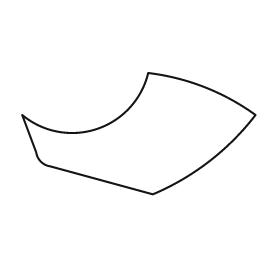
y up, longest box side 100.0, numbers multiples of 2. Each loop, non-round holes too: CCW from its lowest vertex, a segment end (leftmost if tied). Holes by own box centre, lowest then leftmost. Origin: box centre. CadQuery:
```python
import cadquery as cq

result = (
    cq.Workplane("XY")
    .moveTo(6.0, -26.0)
    .threePointArc((30.0, -12.0), (50.0, 8.0))
    .threePointArc((28.0, 20.0), (4.0, 26.0))
    .threePointArc((-18.0, 2.0), (-50.0, 8.0))
    .lineTo(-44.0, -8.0)
    .threePointArc((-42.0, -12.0), (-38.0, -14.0))
    .close()
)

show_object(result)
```